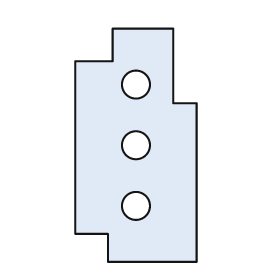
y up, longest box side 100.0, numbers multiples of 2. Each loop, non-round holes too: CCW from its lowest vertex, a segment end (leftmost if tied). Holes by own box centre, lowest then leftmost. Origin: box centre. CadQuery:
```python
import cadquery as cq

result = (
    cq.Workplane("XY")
    .moveTo(-12.0, -50.0)
    .lineTo(26.0, -50.0)
    .lineTo(26.0, 18.0)
    .lineTo(16.0, 18.0)
    .lineTo(16.0, 50.0)
    .lineTo(-10.0, 50.0)
    .lineTo(-10.0, 36.0)
    .lineTo(-26.0, 36.0)
    .lineTo(-26.0, -38.0)
    .lineTo(-12.0, -38.0)
    .close()
    .moveTo(0.0, -26.0)
    .circle(6.0)
    .moveTo(0.0, 0.0)
    .circle(6.0)
    .moveTo(0.0, 26.0)
    .circle(6.0)
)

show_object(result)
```